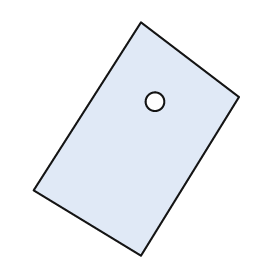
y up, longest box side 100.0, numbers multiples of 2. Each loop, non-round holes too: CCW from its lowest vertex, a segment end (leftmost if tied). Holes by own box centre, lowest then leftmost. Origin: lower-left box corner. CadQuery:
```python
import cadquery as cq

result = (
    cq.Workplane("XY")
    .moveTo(46.0, 0.0)
    .lineTo(88.0, 68.0)
    .lineTo(46.0, 100.0)
    .lineTo(0.0, 28.0)
    .close()
    .moveTo(52.0, 66.0)
    .circle(4.0)
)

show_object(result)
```